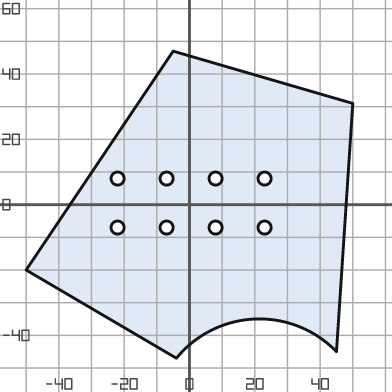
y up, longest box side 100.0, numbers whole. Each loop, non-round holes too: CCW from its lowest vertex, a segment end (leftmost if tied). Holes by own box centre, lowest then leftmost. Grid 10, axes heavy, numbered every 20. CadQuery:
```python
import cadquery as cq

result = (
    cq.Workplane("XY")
    .moveTo(-4.0, -47.0)
    .threePointArc((20.0, -35.0), (45.0, -45.0))
    .lineTo(50.0, 31.0)
    .lineTo(-5.0, 47.0)
    .lineTo(-50.0, -20.0)
    .close()
    .moveTo(-22.0, -7.0)
    .circle(2.0)
    .moveTo(-7.0, -7.0)
    .circle(2.0)
    .moveTo(8.0, -7.0)
    .circle(2.0)
    .moveTo(23.0, -7.0)
    .circle(2.0)
    .moveTo(-22.0, 8.0)
    .circle(2.0)
    .moveTo(-7.0, 8.0)
    .circle(2.0)
    .moveTo(8.0, 8.0)
    .circle(2.0)
    .moveTo(23.0, 8.0)
    .circle(2.0)
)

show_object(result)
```